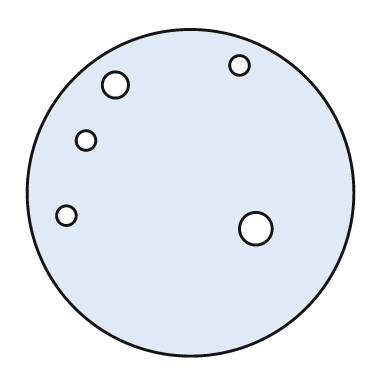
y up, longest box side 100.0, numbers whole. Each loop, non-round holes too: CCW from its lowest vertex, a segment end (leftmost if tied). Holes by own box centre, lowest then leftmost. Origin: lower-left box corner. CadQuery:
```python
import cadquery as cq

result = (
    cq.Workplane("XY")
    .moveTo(50.0, 50.0)
    .circle(50.0)
    .moveTo(70.0, 39.0)
    .circle(5.0)
    .moveTo(12.0, 43.0)
    .circle(3.0)
    .moveTo(18.0, 66.0)
    .circle(3.0)
    .moveTo(27.0, 83.0)
    .circle(4.0)
    .moveTo(65.0, 89.0)
    .circle(3.0)
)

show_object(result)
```